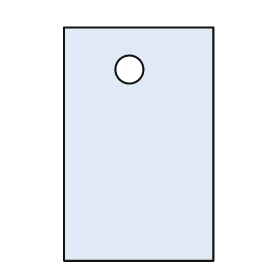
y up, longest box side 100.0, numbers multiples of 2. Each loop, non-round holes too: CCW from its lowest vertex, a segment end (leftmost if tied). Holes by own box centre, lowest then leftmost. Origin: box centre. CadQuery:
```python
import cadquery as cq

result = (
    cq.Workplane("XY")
    .moveTo(-32.0, -50.0)
    .lineTo(32.0, -50.0)
    .lineTo(32.0, 50.0)
    .lineTo(-32.0, 50.0)
    .close()
    .moveTo(-4.0, 32.0)
    .circle(6.0)
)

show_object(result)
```